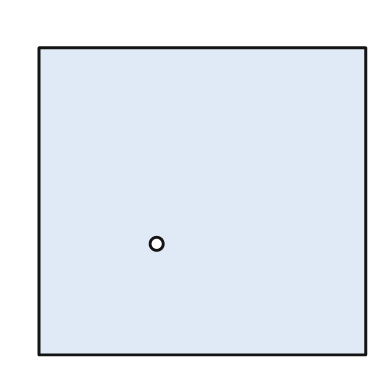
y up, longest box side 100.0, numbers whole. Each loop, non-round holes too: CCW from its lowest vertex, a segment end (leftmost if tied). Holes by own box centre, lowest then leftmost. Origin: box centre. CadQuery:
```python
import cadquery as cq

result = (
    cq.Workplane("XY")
    .moveTo(-50.0, -47.0)
    .lineTo(50.0, -47.0)
    .lineTo(50.0, 47.0)
    .lineTo(-50.0, 47.0)
    .close()
    .moveTo(-14.0, -13.0)
    .circle(2.0)
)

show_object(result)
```